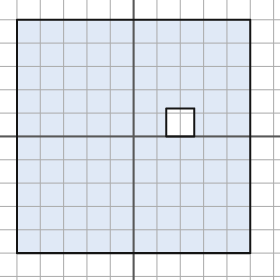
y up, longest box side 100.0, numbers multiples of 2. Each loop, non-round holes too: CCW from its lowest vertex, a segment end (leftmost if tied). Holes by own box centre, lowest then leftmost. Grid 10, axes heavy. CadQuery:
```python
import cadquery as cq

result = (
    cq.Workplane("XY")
    .moveTo(-50.0, -50.0)
    .lineTo(50.0, -50.0)
    .lineTo(50.0, 50.0)
    .lineTo(-50.0, 50.0)
    .close()
    .moveTo(14.0, 0.0)
    .lineTo(26.0, 0.0)
    .lineTo(26.0, 12.0)
    .lineTo(14.0, 12.0)
    .close()
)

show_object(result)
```